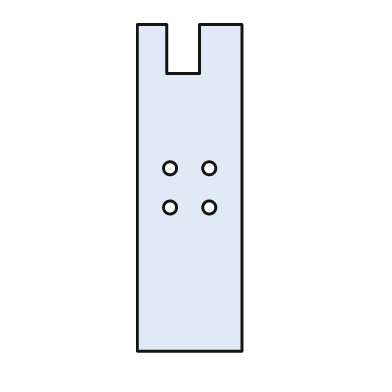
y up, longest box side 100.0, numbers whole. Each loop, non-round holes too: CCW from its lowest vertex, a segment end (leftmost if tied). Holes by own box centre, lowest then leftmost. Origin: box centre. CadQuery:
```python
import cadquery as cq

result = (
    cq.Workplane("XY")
    .moveTo(-16.0, -50.0)
    .lineTo(16.0, -50.0)
    .lineTo(16.0, 50.0)
    .lineTo(3.0, 50.0)
    .lineTo(3.0, 35.0)
    .lineTo(-7.0, 35.0)
    .lineTo(-7.0, 50.0)
    .lineTo(-16.0, 50.0)
    .close()
    .moveTo(-6.0, -6.0)
    .circle(2.0)
    .moveTo(6.0, -6.0)
    .circle(2.0)
    .moveTo(-6.0, 6.0)
    .circle(2.0)
    .moveTo(6.0, 6.0)
    .circle(2.0)
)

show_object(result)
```